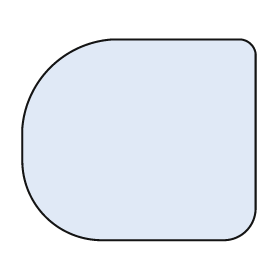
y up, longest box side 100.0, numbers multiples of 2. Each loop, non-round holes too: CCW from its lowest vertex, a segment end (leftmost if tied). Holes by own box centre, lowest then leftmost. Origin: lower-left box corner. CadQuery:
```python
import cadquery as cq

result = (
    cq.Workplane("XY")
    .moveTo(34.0, 0.0)
    .lineTo(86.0, 0.0)
    .threePointArc((96.0, 4.0), (100.0, 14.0))
    .lineTo(100.0, 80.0)
    .threePointArc((98.0, 84.0), (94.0, 86.0))
    .lineTo(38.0, 86.0)
    .threePointArc((12.0, 74.0), (0.0, 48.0))
    .lineTo(0.0, 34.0)
    .threePointArc((10.0, 10.0), (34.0, 0.0))
    .close()
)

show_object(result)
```